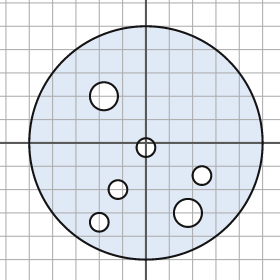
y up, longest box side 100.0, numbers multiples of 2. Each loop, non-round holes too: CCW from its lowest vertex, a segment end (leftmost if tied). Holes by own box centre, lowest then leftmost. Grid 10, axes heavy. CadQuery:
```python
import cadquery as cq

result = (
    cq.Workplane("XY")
    .moveTo(0.0, 0.0)
    .circle(50.0)
    .moveTo(-20.0, -34.0)
    .circle(4.0)
    .moveTo(18.0, -30.0)
    .circle(6.0)
    .moveTo(-12.0, -20.0)
    .circle(4.0)
    .moveTo(24.0, -14.0)
    .circle(4.0)
    .moveTo(0.0, -2.0)
    .circle(4.0)
    .moveTo(-18.0, 20.0)
    .circle(6.0)
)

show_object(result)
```